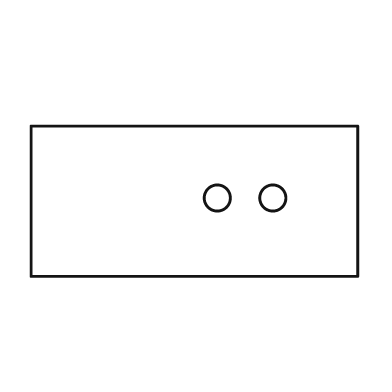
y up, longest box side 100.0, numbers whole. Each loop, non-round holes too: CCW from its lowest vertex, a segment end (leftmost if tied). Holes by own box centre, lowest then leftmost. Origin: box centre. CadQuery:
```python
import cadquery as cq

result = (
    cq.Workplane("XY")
    .moveTo(-50.0, -23.0)
    .lineTo(50.0, -23.0)
    .lineTo(50.0, 23.0)
    .lineTo(-50.0, 23.0)
    .close()
    .moveTo(7.0, 1.0)
    .circle(4.0)
    .moveTo(24.0, 1.0)
    .circle(4.0)
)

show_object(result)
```